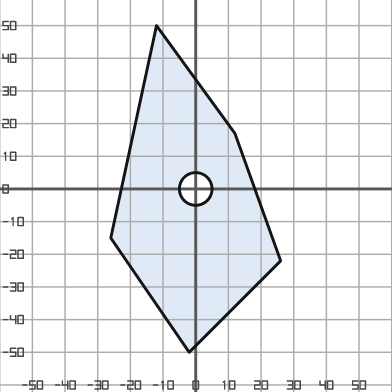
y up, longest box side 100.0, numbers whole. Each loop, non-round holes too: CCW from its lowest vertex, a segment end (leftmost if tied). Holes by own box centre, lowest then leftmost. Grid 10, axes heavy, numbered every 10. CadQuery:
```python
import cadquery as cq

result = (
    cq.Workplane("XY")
    .moveTo(-2.0, -50.0)
    .lineTo(26.0, -22.0)
    .lineTo(12.0, 17.0)
    .lineTo(-12.0, 50.0)
    .lineTo(-26.0, -15.0)
    .close()
    .moveTo(0.0, 0.0)
    .circle(5.0)
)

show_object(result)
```